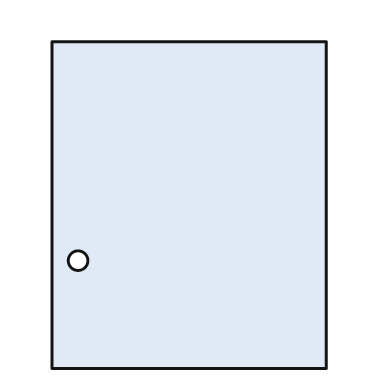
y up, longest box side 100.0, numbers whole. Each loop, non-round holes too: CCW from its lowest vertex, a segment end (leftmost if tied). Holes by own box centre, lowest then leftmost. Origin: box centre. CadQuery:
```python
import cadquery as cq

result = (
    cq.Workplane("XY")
    .moveTo(-42.0, -50.0)
    .lineTo(42.0, -50.0)
    .lineTo(42.0, 50.0)
    .lineTo(-42.0, 50.0)
    .close()
    .moveTo(-34.0, -17.0)
    .circle(3.0)
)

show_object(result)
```